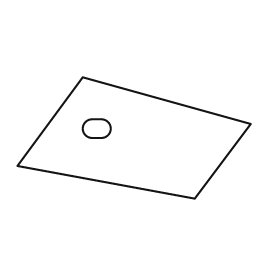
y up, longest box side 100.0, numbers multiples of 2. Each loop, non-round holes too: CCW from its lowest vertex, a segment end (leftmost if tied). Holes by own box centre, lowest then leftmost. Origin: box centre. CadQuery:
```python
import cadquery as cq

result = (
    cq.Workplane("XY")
    .moveTo(26.0, -26.0)
    .lineTo(50.0, 6.0)
    .lineTo(-22.0, 26.0)
    .lineTo(-50.0, -12.0)
    .close()
    .moveTo(-18.0, 0.0)
    .lineTo(-14.0, 0.0)
    .threePointArc((-10.0, 4.0), (-14.0, 8.0))
    .lineTo(-18.0, 8.0)
    .threePointArc((-22.0, 4.0), (-18.0, 0.0))
    .close()
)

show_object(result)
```